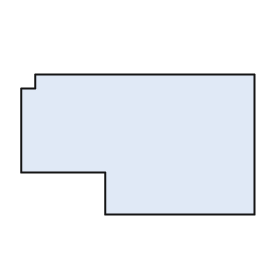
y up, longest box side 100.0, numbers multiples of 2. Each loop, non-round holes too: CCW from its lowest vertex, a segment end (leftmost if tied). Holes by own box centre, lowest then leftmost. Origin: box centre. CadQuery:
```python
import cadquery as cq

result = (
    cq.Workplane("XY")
    .moveTo(-14.0, -30.0)
    .lineTo(50.0, -30.0)
    .lineTo(50.0, 30.0)
    .lineTo(-44.0, 30.0)
    .lineTo(-44.0, 24.0)
    .lineTo(-50.0, 24.0)
    .lineTo(-50.0, -12.0)
    .lineTo(-14.0, -12.0)
    .close()
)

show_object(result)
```